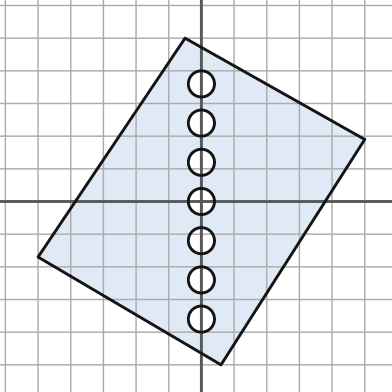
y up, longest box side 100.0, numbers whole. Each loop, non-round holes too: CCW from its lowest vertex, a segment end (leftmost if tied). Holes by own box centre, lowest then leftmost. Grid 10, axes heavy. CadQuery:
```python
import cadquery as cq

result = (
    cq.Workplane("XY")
    .moveTo(6.0, -50.0)
    .lineTo(50.0, 19.0)
    .lineTo(-5.0, 50.0)
    .lineTo(-50.0, -17.0)
    .close()
    .moveTo(0.0, -36.0)
    .circle(4.0)
    .moveTo(0.0, -24.0)
    .circle(4.0)
    .moveTo(0.0, -12.0)
    .circle(4.0)
    .moveTo(0.0, 0.0)
    .circle(4.0)
    .moveTo(0.0, 12.0)
    .circle(4.0)
    .moveTo(0.0, 24.0)
    .circle(4.0)
    .moveTo(0.0, 36.0)
    .circle(4.0)
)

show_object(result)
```